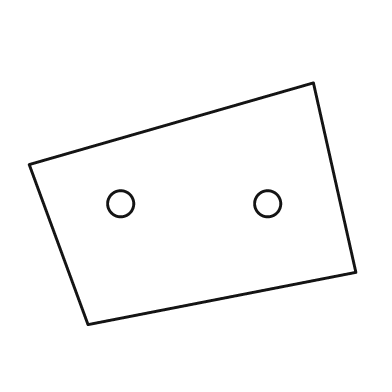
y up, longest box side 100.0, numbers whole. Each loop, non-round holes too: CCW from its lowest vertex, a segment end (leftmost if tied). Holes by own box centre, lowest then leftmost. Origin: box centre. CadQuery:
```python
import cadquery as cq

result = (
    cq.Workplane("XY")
    .moveTo(-32.0, -37.0)
    .lineTo(50.0, -21.0)
    .lineTo(37.0, 37.0)
    .lineTo(-50.0, 12.0)
    .close()
    .moveTo(-22.0, 0.0)
    .circle(4.0)
    .moveTo(23.0, 0.0)
    .circle(4.0)
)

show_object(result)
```